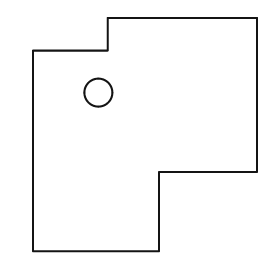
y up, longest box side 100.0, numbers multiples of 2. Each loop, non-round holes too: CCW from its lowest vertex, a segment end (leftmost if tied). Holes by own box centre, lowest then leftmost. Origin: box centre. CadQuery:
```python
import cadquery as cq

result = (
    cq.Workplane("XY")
    .moveTo(-48.0, -50.0)
    .lineTo(6.0, -50.0)
    .lineTo(6.0, -16.0)
    .lineTo(48.0, -16.0)
    .lineTo(48.0, 50.0)
    .lineTo(-16.0, 50.0)
    .lineTo(-16.0, 36.0)
    .lineTo(-48.0, 36.0)
    .close()
    .moveTo(-20.0, 18.0)
    .circle(6.0)
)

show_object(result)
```